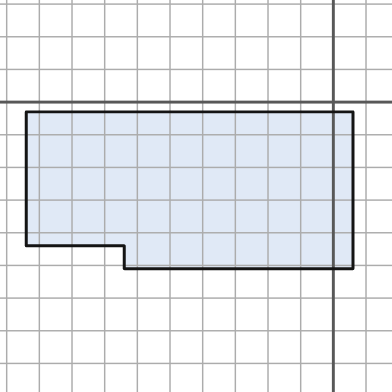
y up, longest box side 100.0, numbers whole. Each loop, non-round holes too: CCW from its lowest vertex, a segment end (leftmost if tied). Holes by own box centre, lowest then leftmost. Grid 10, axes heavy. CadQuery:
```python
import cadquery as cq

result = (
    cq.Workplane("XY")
    .moveTo(-64.0, -51.0)
    .lineTo(6.0, -51.0)
    .lineTo(6.0, -3.0)
    .lineTo(-94.0, -3.0)
    .lineTo(-94.0, -44.0)
    .lineTo(-64.0, -44.0)
    .close()
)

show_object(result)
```